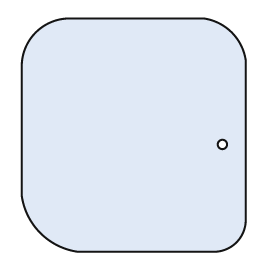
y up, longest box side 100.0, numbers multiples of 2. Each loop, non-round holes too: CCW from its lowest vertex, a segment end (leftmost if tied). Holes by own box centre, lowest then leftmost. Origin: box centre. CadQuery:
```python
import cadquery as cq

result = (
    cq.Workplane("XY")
    .moveTo(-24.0, -50.0)
    .lineTo(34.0, -50.0)
    .threePointArc((44.0, -46.0), (48.0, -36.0))
    .lineTo(48.0, 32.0)
    .threePointArc((42.0, 44.0), (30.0, 50.0))
    .lineTo(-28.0, 50.0)
    .threePointArc((-42.0, 44.0), (-48.0, 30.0))
    .lineTo(-48.0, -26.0)
    .threePointArc((-40.0, -42.0), (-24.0, -50.0))
    .close()
    .moveTo(38.0, -4.0)
    .circle(2.0)
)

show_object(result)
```